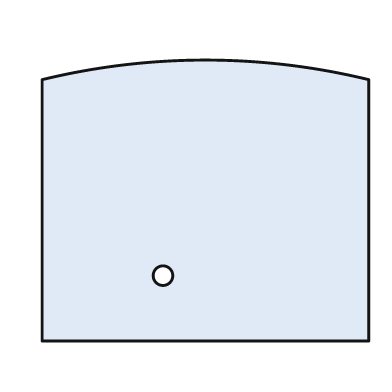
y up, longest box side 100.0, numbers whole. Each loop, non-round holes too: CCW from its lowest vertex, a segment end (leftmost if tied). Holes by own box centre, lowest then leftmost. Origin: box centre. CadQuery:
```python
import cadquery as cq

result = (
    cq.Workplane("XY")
    .moveTo(-50.0, -43.0)
    .lineTo(50.0, -43.0)
    .lineTo(50.0, 37.0)
    .threePointArc((0.0, 43.0), (-50.0, 37.0))
    .close()
    .moveTo(-13.0, -23.0)
    .circle(3.0)
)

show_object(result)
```